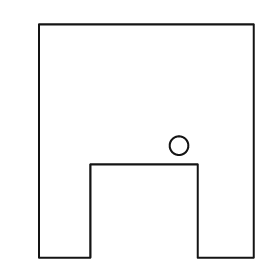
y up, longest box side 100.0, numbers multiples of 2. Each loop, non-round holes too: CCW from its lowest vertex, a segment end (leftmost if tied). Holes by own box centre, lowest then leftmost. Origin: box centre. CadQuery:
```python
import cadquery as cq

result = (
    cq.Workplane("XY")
    .moveTo(-46.0, -50.0)
    .lineTo(-24.0, -50.0)
    .lineTo(-24.0, -10.0)
    .lineTo(22.0, -10.0)
    .lineTo(22.0, -50.0)
    .lineTo(46.0, -50.0)
    .lineTo(46.0, 50.0)
    .lineTo(-46.0, 50.0)
    .close()
    .moveTo(14.0, -2.0)
    .circle(4.0)
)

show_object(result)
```